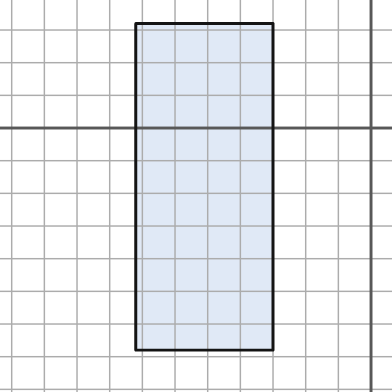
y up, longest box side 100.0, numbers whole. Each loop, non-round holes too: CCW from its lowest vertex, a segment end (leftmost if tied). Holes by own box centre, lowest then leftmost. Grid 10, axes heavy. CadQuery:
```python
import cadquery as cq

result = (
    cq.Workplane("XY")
    .moveTo(-72.0, -68.0)
    .lineTo(-30.0, -68.0)
    .lineTo(-30.0, 32.0)
    .lineTo(-72.0, 32.0)
    .close()
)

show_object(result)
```